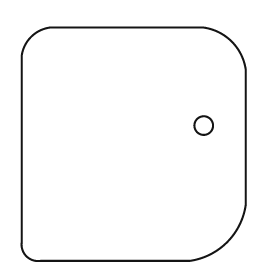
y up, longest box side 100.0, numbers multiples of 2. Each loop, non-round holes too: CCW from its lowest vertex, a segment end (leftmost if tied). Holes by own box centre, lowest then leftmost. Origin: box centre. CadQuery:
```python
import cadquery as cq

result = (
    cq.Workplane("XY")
    .moveTo(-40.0, -50.0)
    .lineTo(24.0, -50.0)
    .threePointArc((40.0, -42.0), (48.0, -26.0))
    .lineTo(48.0, 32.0)
    .threePointArc((42.0, 44.0), (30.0, 50.0))
    .lineTo(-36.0, 50.0)
    .threePointArc((-44.0, 46.0), (-48.0, 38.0))
    .lineTo(-48.0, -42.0)
    .threePointArc((-46.0, -48.0), (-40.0, -50.0))
    .close()
    .moveTo(30.0, 8.0)
    .circle(4.0)
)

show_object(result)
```